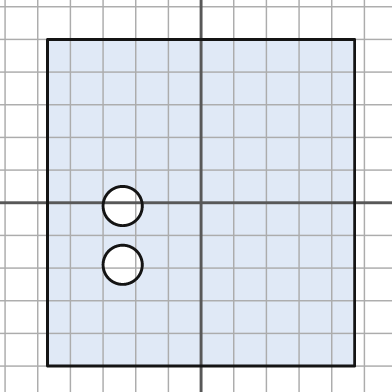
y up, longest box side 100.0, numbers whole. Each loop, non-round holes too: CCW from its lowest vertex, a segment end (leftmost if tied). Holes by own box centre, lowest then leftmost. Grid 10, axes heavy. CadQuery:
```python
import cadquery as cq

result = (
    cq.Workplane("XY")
    .moveTo(-47.0, -50.0)
    .lineTo(47.0, -50.0)
    .lineTo(47.0, 50.0)
    .lineTo(-47.0, 50.0)
    .close()
    .moveTo(-24.0, -19.0)
    .circle(6.0)
    .moveTo(-24.0, -1.0)
    .circle(6.0)
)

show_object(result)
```